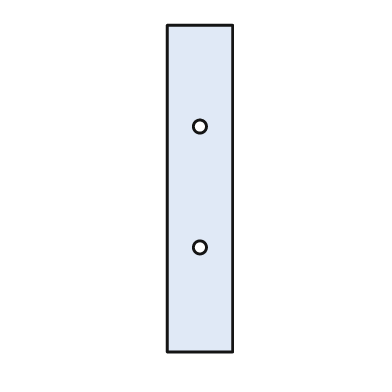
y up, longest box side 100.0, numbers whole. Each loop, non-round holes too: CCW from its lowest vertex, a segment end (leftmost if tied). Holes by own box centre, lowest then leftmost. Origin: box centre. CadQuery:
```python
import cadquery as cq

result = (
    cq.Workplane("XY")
    .moveTo(-10.0, -50.0)
    .lineTo(10.0, -50.0)
    .lineTo(10.0, 50.0)
    .lineTo(-10.0, 50.0)
    .close()
    .moveTo(0.0, -18.0)
    .circle(2.0)
    .moveTo(0.0, 19.0)
    .circle(2.0)
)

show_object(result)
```